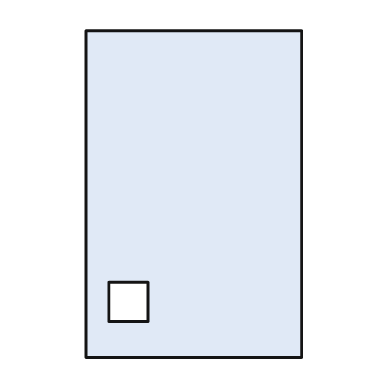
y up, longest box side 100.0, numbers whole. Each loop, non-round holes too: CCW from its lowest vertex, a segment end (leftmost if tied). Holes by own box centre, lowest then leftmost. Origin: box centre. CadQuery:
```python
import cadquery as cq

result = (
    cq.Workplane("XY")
    .moveTo(-33.0, -50.0)
    .lineTo(33.0, -50.0)
    .lineTo(33.0, 50.0)
    .lineTo(-33.0, 50.0)
    .close()
    .moveTo(-26.0, -39.0)
    .lineTo(-14.0, -39.0)
    .lineTo(-14.0, -27.0)
    .lineTo(-26.0, -27.0)
    .close()
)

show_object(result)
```